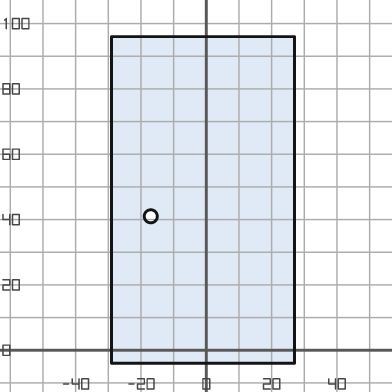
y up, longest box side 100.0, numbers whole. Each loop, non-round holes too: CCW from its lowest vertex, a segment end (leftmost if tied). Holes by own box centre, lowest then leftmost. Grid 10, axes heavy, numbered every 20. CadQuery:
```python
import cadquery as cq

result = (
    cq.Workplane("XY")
    .moveTo(-29.0, -4.0)
    .lineTo(27.0, -4.0)
    .lineTo(27.0, 96.0)
    .lineTo(-29.0, 96.0)
    .close()
    .moveTo(-17.0, 41.0)
    .circle(2.0)
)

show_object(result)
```